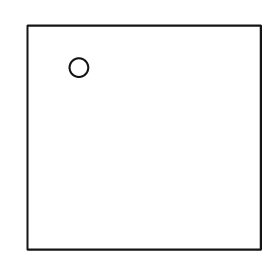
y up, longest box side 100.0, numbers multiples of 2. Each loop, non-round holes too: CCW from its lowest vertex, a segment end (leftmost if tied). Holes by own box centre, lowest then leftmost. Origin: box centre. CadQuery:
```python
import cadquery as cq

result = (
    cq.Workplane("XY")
    .moveTo(-50.0, -48.0)
    .lineTo(50.0, -48.0)
    .lineTo(50.0, 48.0)
    .lineTo(-50.0, 48.0)
    .close()
    .moveTo(-28.0, 30.0)
    .circle(4.0)
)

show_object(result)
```